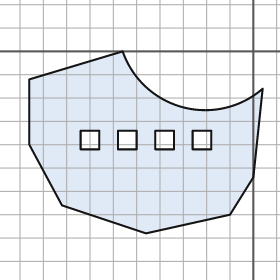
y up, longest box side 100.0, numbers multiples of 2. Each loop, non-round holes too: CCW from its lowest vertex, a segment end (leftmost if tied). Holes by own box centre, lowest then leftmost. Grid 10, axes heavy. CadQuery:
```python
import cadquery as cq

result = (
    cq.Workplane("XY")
    .moveTo(-46.0, -78.0)
    .lineTo(-10.0, -70.0)
    .lineTo(0.0, -54.0)
    .lineTo(4.0, -16.0)
    .threePointArc((-30.0, -24.0), (-56.0, 0.0))
    .lineTo(-96.0, -12.0)
    .lineTo(-96.0, -40.0)
    .lineTo(-82.0, -66.0)
    .close()
    .moveTo(-74.0, -42.0)
    .lineTo(-66.0, -42.0)
    .lineTo(-66.0, -34.0)
    .lineTo(-74.0, -34.0)
    .close()
    .moveTo(-58.0, -42.0)
    .lineTo(-50.0, -42.0)
    .lineTo(-50.0, -34.0)
    .lineTo(-58.0, -34.0)
    .close()
    .moveTo(-42.0, -42.0)
    .lineTo(-34.0, -42.0)
    .lineTo(-34.0, -34.0)
    .lineTo(-42.0, -34.0)
    .close()
    .moveTo(-26.0, -42.0)
    .lineTo(-18.0, -42.0)
    .lineTo(-18.0, -34.0)
    .lineTo(-26.0, -34.0)
    .close()
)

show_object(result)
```